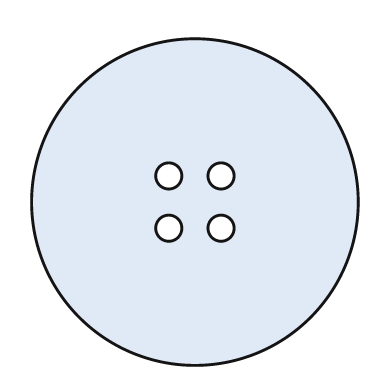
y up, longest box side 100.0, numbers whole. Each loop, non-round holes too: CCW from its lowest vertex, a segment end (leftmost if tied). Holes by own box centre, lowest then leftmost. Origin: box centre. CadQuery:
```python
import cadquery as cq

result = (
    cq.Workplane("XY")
    .moveTo(0.0, 0.0)
    .circle(50.0)
    .moveTo(-8.0, -8.0)
    .circle(4.0)
    .moveTo(8.0, -8.0)
    .circle(4.0)
    .moveTo(-8.0, 8.0)
    .circle(4.0)
    .moveTo(8.0, 8.0)
    .circle(4.0)
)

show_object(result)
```